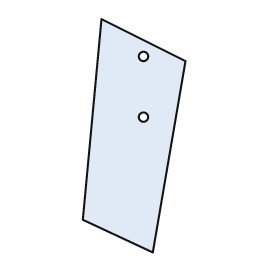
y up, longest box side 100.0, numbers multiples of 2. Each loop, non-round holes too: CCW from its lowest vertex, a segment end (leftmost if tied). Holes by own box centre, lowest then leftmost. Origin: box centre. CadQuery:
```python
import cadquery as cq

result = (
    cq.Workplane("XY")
    .moveTo(8.0, -50.0)
    .lineTo(22.0, 32.0)
    .lineTo(-14.0, 50.0)
    .lineTo(-22.0, -36.0)
    .close()
    .moveTo(4.0, 8.0)
    .circle(2.0)
    .moveTo(4.0, 34.0)
    .circle(2.0)
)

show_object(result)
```